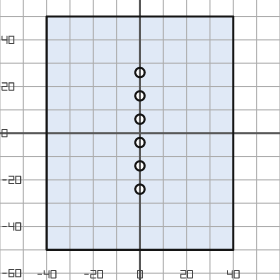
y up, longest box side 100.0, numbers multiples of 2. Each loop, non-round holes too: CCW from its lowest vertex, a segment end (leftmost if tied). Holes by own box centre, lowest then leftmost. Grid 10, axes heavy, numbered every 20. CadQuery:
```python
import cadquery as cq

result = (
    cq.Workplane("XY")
    .moveTo(-40.0, -50.0)
    .lineTo(40.0, -50.0)
    .lineTo(40.0, 50.0)
    .lineTo(-40.0, 50.0)
    .close()
    .moveTo(0.0, -24.0)
    .circle(2.0)
    .moveTo(0.0, -14.0)
    .circle(2.0)
    .moveTo(0.0, -4.0)
    .circle(2.0)
    .moveTo(0.0, 6.0)
    .circle(2.0)
    .moveTo(0.0, 16.0)
    .circle(2.0)
    .moveTo(0.0, 26.0)
    .circle(2.0)
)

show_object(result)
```